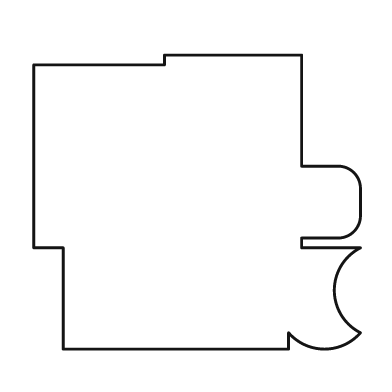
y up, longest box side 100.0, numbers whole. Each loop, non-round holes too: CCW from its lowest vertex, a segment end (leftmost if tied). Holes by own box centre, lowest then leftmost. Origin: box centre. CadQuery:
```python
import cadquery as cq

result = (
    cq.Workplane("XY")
    .moveTo(-41.0, -45.0)
    .lineTo(28.0, -45.0)
    .lineTo(28.0, -40.0)
    .threePointArc((39.0, -45.0), (50.0, -40.0))
    .threePointArc((42.0, -27.0), (50.0, -14.0))
    .lineTo(32.0, -14.0)
    .lineTo(32.0, -11.0)
    .lineTo(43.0, -11.0)
    .threePointArc((48.0, -9.0), (50.0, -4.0))
    .lineTo(50.0, 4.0)
    .threePointArc((48.0, 9.0), (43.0, 11.0))
    .lineTo(32.0, 11.0)
    .lineTo(32.0, 45.0)
    .lineTo(-10.0, 45.0)
    .lineTo(-10.0, 42.0)
    .lineTo(-50.0, 42.0)
    .lineTo(-50.0, -14.0)
    .lineTo(-41.0, -14.0)
    .close()
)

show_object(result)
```